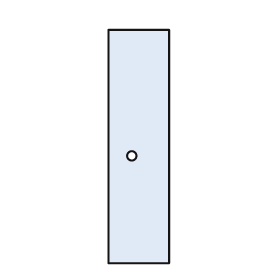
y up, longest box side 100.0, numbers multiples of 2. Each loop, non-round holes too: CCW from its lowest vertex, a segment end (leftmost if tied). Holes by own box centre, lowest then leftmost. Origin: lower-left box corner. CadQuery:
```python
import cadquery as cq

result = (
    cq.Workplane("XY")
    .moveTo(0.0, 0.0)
    .lineTo(26.0, 0.0)
    .lineTo(26.0, 100.0)
    .lineTo(0.0, 100.0)
    .close()
    .moveTo(10.0, 46.0)
    .circle(2.0)
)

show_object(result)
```